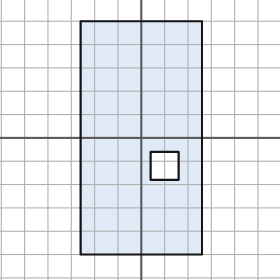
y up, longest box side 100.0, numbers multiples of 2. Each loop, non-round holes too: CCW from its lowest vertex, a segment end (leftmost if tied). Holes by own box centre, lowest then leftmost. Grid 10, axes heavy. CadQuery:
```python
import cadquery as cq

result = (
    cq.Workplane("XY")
    .moveTo(-26.0, -50.0)
    .lineTo(26.0, -50.0)
    .lineTo(26.0, 50.0)
    .lineTo(-26.0, 50.0)
    .close()
    .moveTo(4.0, -18.0)
    .lineTo(16.0, -18.0)
    .lineTo(16.0, -6.0)
    .lineTo(4.0, -6.0)
    .close()
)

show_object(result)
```